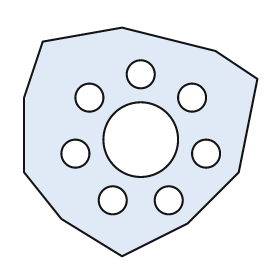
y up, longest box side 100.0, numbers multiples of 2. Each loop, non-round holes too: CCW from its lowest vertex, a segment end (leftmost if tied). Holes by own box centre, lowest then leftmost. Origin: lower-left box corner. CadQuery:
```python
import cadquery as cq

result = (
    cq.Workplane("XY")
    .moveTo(42.0, 0.0)
    .lineTo(70.0, 14.0)
    .lineTo(92.0, 36.0)
    .lineTo(100.0, 76.0)
    .lineTo(82.0, 88.0)
    .lineTo(42.0, 98.0)
    .lineTo(8.0, 92.0)
    .lineTo(0.0, 68.0)
    .lineTo(0.0, 36.0)
    .lineTo(16.0, 16.0)
    .close()
    .moveTo(38.0, 24.0)
    .circle(6.0)
    .moveTo(62.0, 24.0)
    .circle(6.0)
    .moveTo(22.0, 44.0)
    .circle(6.0)
    .moveTo(78.0, 44.0)
    .circle(6.0)
    .moveTo(50.0, 50.0)
    .circle(16.0)
    .moveTo(28.0, 68.0)
    .circle(6.0)
    .moveTo(72.0, 68.0)
    .circle(6.0)
    .moveTo(50.0, 78.0)
    .circle(6.0)
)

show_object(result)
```